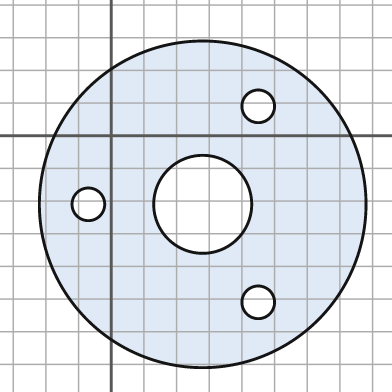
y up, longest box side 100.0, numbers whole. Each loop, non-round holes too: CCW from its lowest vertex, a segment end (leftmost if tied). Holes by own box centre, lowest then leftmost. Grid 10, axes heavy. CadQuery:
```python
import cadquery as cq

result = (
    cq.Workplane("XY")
    .moveTo(28.0, -21.0)
    .circle(50.0)
    .moveTo(45.0, -51.0)
    .circle(5.0)
    .moveTo(-7.0, -21.0)
    .circle(5.0)
    .moveTo(28.0, -21.0)
    .circle(15.0)
    .moveTo(45.0, 9.0)
    .circle(5.0)
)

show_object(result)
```